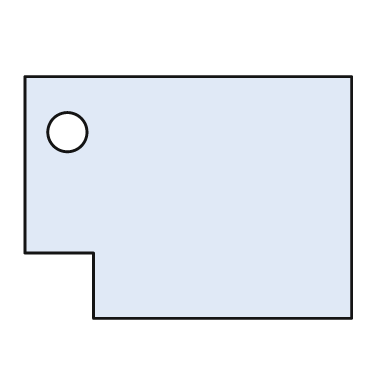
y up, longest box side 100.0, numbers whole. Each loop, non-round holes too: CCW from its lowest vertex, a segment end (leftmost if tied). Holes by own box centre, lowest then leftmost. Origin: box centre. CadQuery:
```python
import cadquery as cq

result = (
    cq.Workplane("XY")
    .moveTo(-29.0, -37.0)
    .lineTo(50.0, -37.0)
    .lineTo(50.0, 37.0)
    .lineTo(-50.0, 37.0)
    .lineTo(-50.0, -17.0)
    .lineTo(-29.0, -17.0)
    .close()
    .moveTo(-37.0, 20.0)
    .circle(6.0)
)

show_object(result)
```